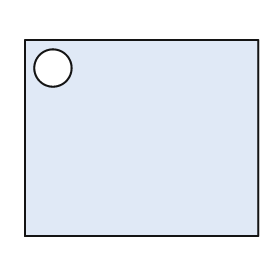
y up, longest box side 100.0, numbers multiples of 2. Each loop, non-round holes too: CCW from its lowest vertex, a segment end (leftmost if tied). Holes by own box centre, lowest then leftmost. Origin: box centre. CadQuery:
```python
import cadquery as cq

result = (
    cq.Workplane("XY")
    .moveTo(-50.0, -42.0)
    .lineTo(50.0, -42.0)
    .lineTo(50.0, 42.0)
    .lineTo(-50.0, 42.0)
    .close()
    .moveTo(-38.0, 30.0)
    .circle(8.0)
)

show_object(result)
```